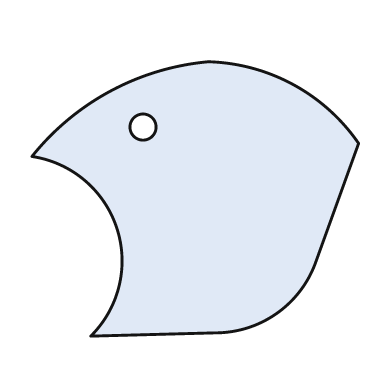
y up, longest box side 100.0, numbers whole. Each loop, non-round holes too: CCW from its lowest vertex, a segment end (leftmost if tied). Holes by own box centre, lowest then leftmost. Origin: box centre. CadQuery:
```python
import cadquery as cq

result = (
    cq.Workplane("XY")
    .moveTo(-32.0, -42.0)
    .lineTo(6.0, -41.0)
    .threePointArc((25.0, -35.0), (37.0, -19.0))
    .lineTo(50.0, 17.0)
    .threePointArc((30.0, 35.0), (4.0, 42.0))
    .threePointArc((-26.0, 33.0), (-50.0, 13.0))
    .threePointArc((-24.0, -9.0), (-32.0, -42.0))
    .close()
    .moveTo(-16.0, 22.0)
    .circle(4.0)
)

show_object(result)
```